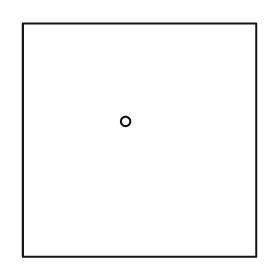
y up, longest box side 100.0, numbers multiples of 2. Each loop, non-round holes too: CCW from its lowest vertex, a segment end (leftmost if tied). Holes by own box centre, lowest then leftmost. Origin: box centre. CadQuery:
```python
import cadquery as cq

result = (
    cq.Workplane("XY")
    .moveTo(-50.0, -50.0)
    .lineTo(50.0, -50.0)
    .lineTo(50.0, 50.0)
    .lineTo(-50.0, 50.0)
    .close()
    .moveTo(-6.0, 8.0)
    .circle(2.0)
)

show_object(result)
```